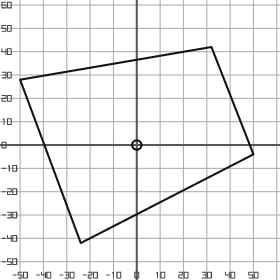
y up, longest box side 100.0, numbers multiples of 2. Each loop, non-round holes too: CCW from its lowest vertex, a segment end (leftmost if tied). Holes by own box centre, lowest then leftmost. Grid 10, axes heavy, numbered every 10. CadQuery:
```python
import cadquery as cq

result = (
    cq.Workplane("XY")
    .moveTo(-24.0, -42.0)
    .lineTo(50.0, -4.0)
    .lineTo(32.0, 42.0)
    .lineTo(-50.0, 28.0)
    .close()
    .moveTo(0.0, 0.0)
    .circle(2.0)
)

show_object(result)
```